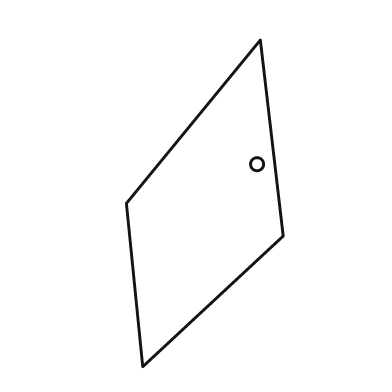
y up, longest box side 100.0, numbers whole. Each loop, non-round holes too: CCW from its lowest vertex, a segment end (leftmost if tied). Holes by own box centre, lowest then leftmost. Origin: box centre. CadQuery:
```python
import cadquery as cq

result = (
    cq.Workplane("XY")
    .moveTo(-19.0, -50.0)
    .lineTo(24.0, -10.0)
    .lineTo(17.0, 50.0)
    .lineTo(-24.0, 0.0)
    .close()
    .moveTo(16.0, 12.0)
    .circle(2.0)
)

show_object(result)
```